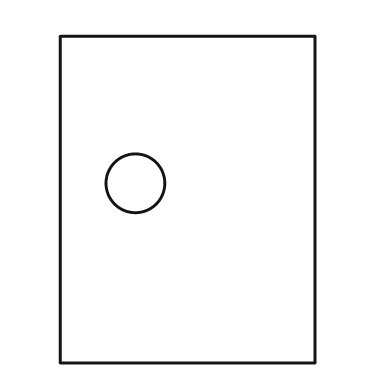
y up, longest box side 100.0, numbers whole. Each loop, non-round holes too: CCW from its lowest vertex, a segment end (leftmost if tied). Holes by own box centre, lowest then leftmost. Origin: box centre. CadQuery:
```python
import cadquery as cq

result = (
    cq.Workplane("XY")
    .moveTo(-39.0, -50.0)
    .lineTo(39.0, -50.0)
    .lineTo(39.0, 50.0)
    .lineTo(-39.0, 50.0)
    .close()
    .moveTo(-16.0, 5.0)
    .circle(9.0)
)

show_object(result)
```